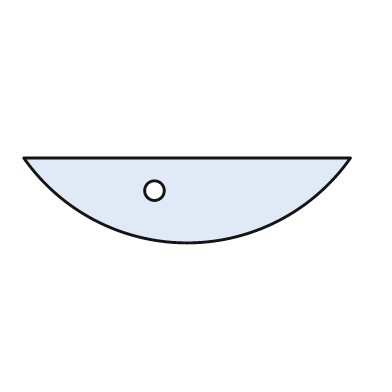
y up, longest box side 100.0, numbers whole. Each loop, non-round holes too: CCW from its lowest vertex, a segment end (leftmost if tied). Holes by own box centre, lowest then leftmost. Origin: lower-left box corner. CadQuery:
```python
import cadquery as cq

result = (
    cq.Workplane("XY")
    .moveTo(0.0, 26.0)
    .threePointArc((50.0, 0.0), (100.0, 26.0))
    .close()
    .moveTo(40.0, 16.0)
    .circle(3.0)
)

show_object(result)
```